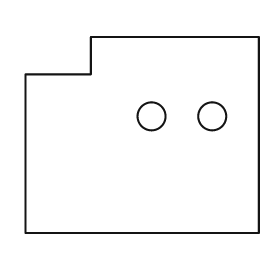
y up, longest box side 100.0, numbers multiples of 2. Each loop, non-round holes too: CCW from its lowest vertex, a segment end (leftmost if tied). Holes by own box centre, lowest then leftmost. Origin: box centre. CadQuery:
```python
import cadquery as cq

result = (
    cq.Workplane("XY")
    .moveTo(-50.0, -42.0)
    .lineTo(50.0, -42.0)
    .lineTo(50.0, 42.0)
    .lineTo(-22.0, 42.0)
    .lineTo(-22.0, 26.0)
    .lineTo(-50.0, 26.0)
    .close()
    .moveTo(4.0, 8.0)
    .circle(6.0)
    .moveTo(30.0, 8.0)
    .circle(6.0)
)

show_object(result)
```